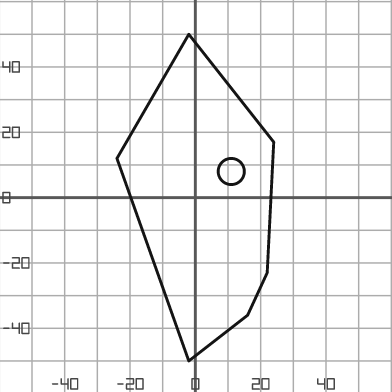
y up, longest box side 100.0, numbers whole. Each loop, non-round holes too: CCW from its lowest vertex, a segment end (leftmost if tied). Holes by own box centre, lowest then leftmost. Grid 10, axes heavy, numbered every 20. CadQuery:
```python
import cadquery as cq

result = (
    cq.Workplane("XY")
    .moveTo(-2.0, -50.0)
    .lineTo(16.0, -36.0)
    .lineTo(22.0, -23.0)
    .lineTo(24.0, 17.0)
    .lineTo(-2.0, 50.0)
    .lineTo(-24.0, 12.0)
    .close()
    .moveTo(11.0, 8.0)
    .circle(4.0)
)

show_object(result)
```